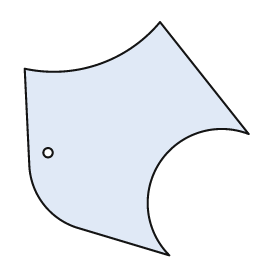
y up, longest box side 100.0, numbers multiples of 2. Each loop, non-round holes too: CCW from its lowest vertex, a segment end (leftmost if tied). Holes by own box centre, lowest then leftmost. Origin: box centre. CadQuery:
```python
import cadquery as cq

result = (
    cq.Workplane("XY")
    .moveTo(14.0, -50.0)
    .threePointArc((10.0, -10.0), (48.0, 2.0))
    .lineTo(10.0, 50.0)
    .threePointArc((-16.0, 32.0), (-48.0, 30.0))
    .lineTo(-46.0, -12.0)
    .threePointArc((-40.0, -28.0), (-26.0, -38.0))
    .close()
    .moveTo(-38.0, -6.0)
    .circle(2.0)
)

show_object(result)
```